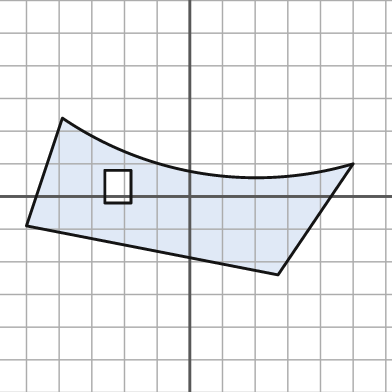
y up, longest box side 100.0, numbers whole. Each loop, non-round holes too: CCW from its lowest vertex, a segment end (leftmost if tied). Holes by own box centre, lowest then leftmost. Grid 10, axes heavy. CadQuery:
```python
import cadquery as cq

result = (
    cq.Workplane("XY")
    .moveTo(27.0, -24.0)
    .lineTo(50.0, 10.0)
    .threePointArc((4.0, 7.0), (-39.0, 24.0))
    .lineTo(-50.0, -9.0)
    .close()
    .moveTo(-26.0, -2.0)
    .lineTo(-18.0, -2.0)
    .lineTo(-18.0, 8.0)
    .lineTo(-26.0, 8.0)
    .close()
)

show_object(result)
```